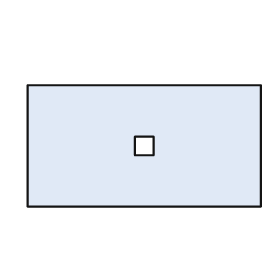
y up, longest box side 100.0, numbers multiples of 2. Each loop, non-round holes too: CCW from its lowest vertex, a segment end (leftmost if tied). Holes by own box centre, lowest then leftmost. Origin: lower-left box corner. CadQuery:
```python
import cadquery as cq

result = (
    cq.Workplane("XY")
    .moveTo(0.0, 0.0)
    .lineTo(100.0, 0.0)
    .lineTo(100.0, 52.0)
    .lineTo(0.0, 52.0)
    .close()
    .moveTo(46.0, 22.0)
    .lineTo(54.0, 22.0)
    .lineTo(54.0, 30.0)
    .lineTo(46.0, 30.0)
    .close()
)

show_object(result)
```